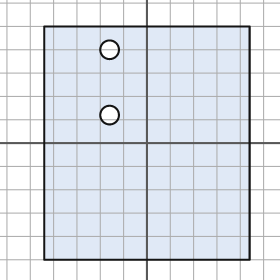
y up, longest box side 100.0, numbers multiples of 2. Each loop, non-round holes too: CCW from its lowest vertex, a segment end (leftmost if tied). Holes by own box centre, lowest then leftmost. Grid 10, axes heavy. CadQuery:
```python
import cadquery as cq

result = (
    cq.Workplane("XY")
    .moveTo(-44.0, -50.0)
    .lineTo(44.0, -50.0)
    .lineTo(44.0, 50.0)
    .lineTo(-44.0, 50.0)
    .close()
    .moveTo(-16.0, 12.0)
    .circle(4.0)
    .moveTo(-16.0, 40.0)
    .circle(4.0)
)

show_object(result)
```